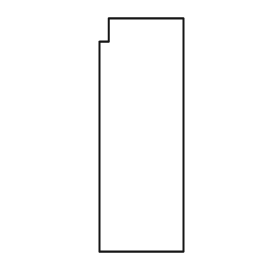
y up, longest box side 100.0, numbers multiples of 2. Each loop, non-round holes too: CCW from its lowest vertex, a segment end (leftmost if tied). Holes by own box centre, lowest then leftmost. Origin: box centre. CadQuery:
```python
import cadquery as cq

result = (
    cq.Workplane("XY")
    .moveTo(-18.0, -50.0)
    .lineTo(18.0, -50.0)
    .lineTo(18.0, 50.0)
    .lineTo(-14.0, 50.0)
    .lineTo(-14.0, 40.0)
    .lineTo(-18.0, 40.0)
    .close()
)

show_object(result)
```